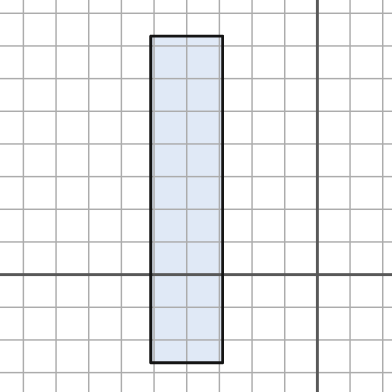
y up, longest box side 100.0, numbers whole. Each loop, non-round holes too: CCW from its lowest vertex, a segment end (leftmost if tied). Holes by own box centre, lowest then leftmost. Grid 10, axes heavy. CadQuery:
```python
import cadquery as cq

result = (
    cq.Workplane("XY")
    .moveTo(-51.0, -27.0)
    .lineTo(-29.0, -27.0)
    .lineTo(-29.0, 73.0)
    .lineTo(-51.0, 73.0)
    .close()
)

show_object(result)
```